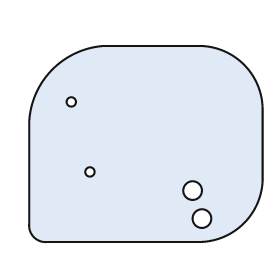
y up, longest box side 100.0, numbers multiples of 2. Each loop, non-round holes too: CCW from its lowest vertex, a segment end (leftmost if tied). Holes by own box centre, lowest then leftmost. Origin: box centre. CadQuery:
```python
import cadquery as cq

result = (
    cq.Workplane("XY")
    .moveTo(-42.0, -42.0)
    .lineTo(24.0, -42.0)
    .threePointArc((42.0, -34.0), (50.0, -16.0))
    .lineTo(50.0, 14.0)
    .threePointArc((42.0, 34.0), (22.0, 42.0))
    .lineTo(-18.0, 42.0)
    .threePointArc((-40.0, 32.0), (-50.0, 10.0))
    .lineTo(-50.0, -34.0)
    .threePointArc((-48.0, -40.0), (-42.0, -42.0))
    .close()
    .moveTo(24.0, -32.0)
    .circle(4.0)
    .moveTo(20.0, -20.0)
    .circle(4.0)
    .moveTo(-24.0, -12.0)
    .circle(2.0)
    .moveTo(-32.0, 18.0)
    .circle(2.0)
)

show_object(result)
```